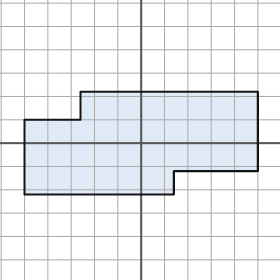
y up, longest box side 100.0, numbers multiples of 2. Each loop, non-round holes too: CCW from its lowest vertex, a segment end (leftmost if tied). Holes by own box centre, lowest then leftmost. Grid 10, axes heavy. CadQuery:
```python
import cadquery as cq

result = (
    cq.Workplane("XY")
    .moveTo(-50.0, -22.0)
    .lineTo(14.0, -22.0)
    .lineTo(14.0, -12.0)
    .lineTo(50.0, -12.0)
    .lineTo(50.0, 22.0)
    .lineTo(-26.0, 22.0)
    .lineTo(-26.0, 10.0)
    .lineTo(-50.0, 10.0)
    .close()
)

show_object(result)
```